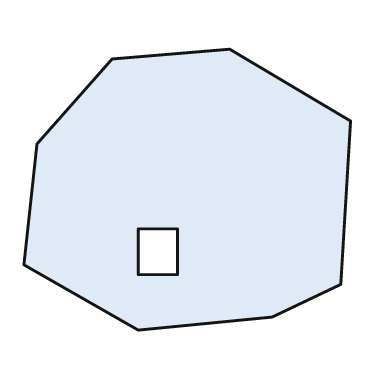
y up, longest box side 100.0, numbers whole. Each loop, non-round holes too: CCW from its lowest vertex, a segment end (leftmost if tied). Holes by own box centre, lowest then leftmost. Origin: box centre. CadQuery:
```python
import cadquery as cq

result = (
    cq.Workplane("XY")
    .moveTo(-15.0, -43.0)
    .lineTo(26.0, -39.0)
    .lineTo(47.0, -29.0)
    .lineTo(50.0, 21.0)
    .lineTo(13.0, 43.0)
    .lineTo(-23.0, 40.0)
    .lineTo(-46.0, 14.0)
    .lineTo(-50.0, -23.0)
    .close()
    .moveTo(-15.0, -26.0)
    .lineTo(-3.0, -26.0)
    .lineTo(-3.0, -12.0)
    .lineTo(-15.0, -12.0)
    .close()
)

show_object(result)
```